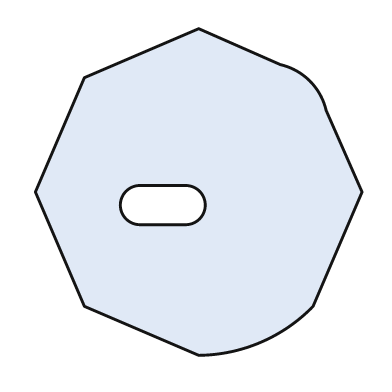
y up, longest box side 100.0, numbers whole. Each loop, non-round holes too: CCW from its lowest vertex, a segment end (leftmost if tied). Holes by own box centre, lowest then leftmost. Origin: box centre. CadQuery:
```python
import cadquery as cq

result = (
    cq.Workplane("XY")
    .moveTo(0.0, -50.0)
    .threePointArc((19.0, -46.0), (35.0, -35.0))
    .lineTo(50.0, 0.0)
    .lineTo(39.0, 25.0)
    .threePointArc((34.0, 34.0), (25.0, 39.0))
    .lineTo(0.0, 50.0)
    .lineTo(-35.0, 35.0)
    .lineTo(-50.0, 0.0)
    .lineTo(-35.0, -35.0)
    .close()
    .moveTo(-18.0, -10.0)
    .lineTo(-4.0, -10.0)
    .threePointArc((2.0, -4.0), (-4.0, 2.0))
    .lineTo(-18.0, 2.0)
    .threePointArc((-24.0, -4.0), (-18.0, -10.0))
    .close()
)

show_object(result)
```